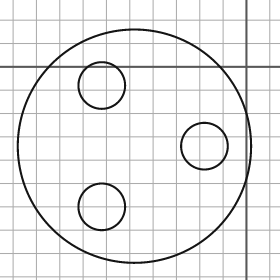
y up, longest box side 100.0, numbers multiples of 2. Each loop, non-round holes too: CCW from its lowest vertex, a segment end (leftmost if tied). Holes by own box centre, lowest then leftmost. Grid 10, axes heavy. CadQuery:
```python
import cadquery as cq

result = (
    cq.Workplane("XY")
    .moveTo(-48.0, -34.0)
    .circle(50.0)
    .moveTo(-62.0, -60.0)
    .circle(10.0)
    .moveTo(-18.0, -34.0)
    .circle(10.0)
    .moveTo(-62.0, -8.0)
    .circle(10.0)
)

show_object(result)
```